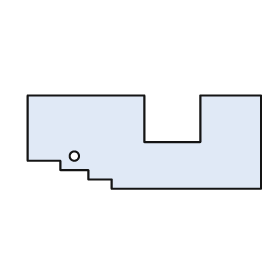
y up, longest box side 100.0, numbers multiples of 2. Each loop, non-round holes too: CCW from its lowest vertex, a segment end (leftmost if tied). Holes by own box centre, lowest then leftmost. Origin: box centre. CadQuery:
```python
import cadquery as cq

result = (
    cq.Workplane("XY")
    .moveTo(-14.0, -20.0)
    .lineTo(50.0, -20.0)
    .lineTo(50.0, 20.0)
    .lineTo(24.0, 20.0)
    .lineTo(24.0, 0.0)
    .lineTo(0.0, 0.0)
    .lineTo(0.0, 20.0)
    .lineTo(-50.0, 20.0)
    .lineTo(-50.0, -8.0)
    .lineTo(-36.0, -8.0)
    .lineTo(-36.0, -12.0)
    .lineTo(-24.0, -12.0)
    .lineTo(-24.0, -16.0)
    .lineTo(-14.0, -16.0)
    .close()
    .moveTo(-30.0, -6.0)
    .circle(2.0)
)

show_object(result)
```